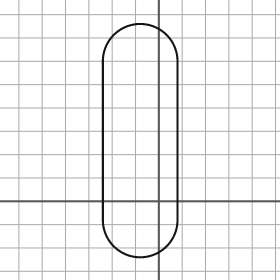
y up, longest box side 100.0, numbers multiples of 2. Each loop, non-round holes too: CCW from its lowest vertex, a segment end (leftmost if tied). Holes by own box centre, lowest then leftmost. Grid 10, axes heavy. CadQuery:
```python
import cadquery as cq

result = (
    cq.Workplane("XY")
    .moveTo(-24.0, -8.0)
    .threePointArc((-8.0, -24.0), (8.0, -8.0))
    .lineTo(8.0, 60.0)
    .threePointArc((-8.0, 76.0), (-24.0, 60.0))
    .close()
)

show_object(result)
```